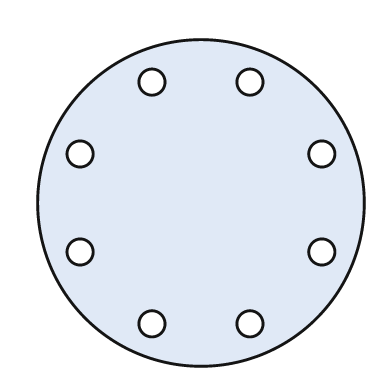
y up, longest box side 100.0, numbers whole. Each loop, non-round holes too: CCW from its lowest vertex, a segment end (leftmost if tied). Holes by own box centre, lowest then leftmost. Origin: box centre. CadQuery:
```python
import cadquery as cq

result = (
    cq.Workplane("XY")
    .moveTo(0.0, 0.0)
    .circle(50.0)
    .moveTo(-15.0, -37.0)
    .circle(4.0)
    .moveTo(15.0, -37.0)
    .circle(4.0)
    .moveTo(-37.0, -15.0)
    .circle(4.0)
    .moveTo(37.0, -15.0)
    .circle(4.0)
    .moveTo(-37.0, 15.0)
    .circle(4.0)
    .moveTo(37.0, 15.0)
    .circle(4.0)
    .moveTo(-15.0, 37.0)
    .circle(4.0)
    .moveTo(15.0, 37.0)
    .circle(4.0)
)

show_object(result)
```